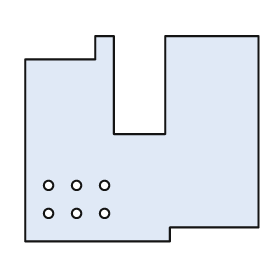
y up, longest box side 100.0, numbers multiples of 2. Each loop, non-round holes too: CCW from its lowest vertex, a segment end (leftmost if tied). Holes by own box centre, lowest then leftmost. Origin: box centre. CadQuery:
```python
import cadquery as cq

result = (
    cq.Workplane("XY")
    .moveTo(-50.0, -44.0)
    .lineTo(12.0, -44.0)
    .lineTo(12.0, -38.0)
    .lineTo(50.0, -38.0)
    .lineTo(50.0, 44.0)
    .lineTo(10.0, 44.0)
    .lineTo(10.0, 2.0)
    .lineTo(-12.0, 2.0)
    .lineTo(-12.0, 44.0)
    .lineTo(-20.0, 44.0)
    .lineTo(-20.0, 34.0)
    .lineTo(-50.0, 34.0)
    .close()
    .moveTo(-40.0, -32.0)
    .circle(2.0)
    .moveTo(-28.0, -32.0)
    .circle(2.0)
    .moveTo(-16.0, -32.0)
    .circle(2.0)
    .moveTo(-40.0, -20.0)
    .circle(2.0)
    .moveTo(-28.0, -20.0)
    .circle(2.0)
    .moveTo(-16.0, -20.0)
    .circle(2.0)
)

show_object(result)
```